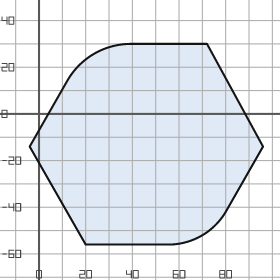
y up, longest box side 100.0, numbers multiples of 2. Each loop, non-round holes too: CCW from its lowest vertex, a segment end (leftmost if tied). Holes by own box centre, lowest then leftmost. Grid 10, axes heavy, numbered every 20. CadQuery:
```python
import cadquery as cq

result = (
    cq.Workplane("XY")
    .moveTo(20.0, -56.0)
    .lineTo(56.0, -56.0)
    .threePointArc((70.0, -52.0), (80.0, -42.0))
    .lineTo(96.0, -14.0)
    .lineTo(72.0, 30.0)
    .lineTo(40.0, 30.0)
    .threePointArc((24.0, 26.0), (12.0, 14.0))
    .lineTo(-4.0, -14.0)
    .close()
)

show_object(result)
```